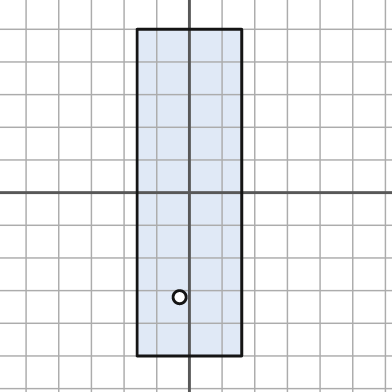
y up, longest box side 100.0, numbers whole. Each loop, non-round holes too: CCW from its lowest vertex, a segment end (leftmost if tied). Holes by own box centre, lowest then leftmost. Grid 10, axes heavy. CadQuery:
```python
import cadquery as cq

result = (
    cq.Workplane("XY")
    .moveTo(-16.0, -50.0)
    .lineTo(16.0, -50.0)
    .lineTo(16.0, 50.0)
    .lineTo(-16.0, 50.0)
    .close()
    .moveTo(-3.0, -32.0)
    .circle(2.0)
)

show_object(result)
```